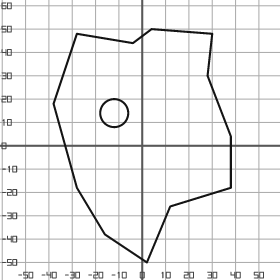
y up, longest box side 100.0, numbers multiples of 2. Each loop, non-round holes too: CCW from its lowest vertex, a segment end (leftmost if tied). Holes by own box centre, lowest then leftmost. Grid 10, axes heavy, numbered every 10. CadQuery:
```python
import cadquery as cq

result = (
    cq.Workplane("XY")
    .moveTo(2.0, -50.0)
    .lineTo(12.0, -26.0)
    .lineTo(38.0, -18.0)
    .lineTo(38.0, 4.0)
    .lineTo(28.0, 30.0)
    .lineTo(30.0, 48.0)
    .lineTo(4.0, 50.0)
    .lineTo(-4.0, 44.0)
    .lineTo(-28.0, 48.0)
    .lineTo(-38.0, 18.0)
    .lineTo(-28.0, -18.0)
    .lineTo(-16.0, -38.0)
    .close()
    .moveTo(-12.0, 14.0)
    .circle(6.0)
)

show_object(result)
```